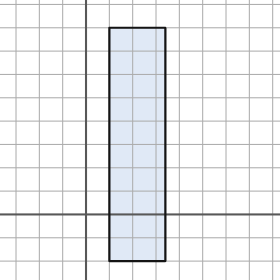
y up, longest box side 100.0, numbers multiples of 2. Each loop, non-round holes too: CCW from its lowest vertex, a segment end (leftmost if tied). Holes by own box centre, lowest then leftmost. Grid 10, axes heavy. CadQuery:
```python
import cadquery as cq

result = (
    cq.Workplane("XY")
    .moveTo(10.0, -20.0)
    .lineTo(34.0, -20.0)
    .lineTo(34.0, 80.0)
    .lineTo(10.0, 80.0)
    .close()
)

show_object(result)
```